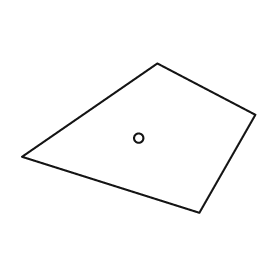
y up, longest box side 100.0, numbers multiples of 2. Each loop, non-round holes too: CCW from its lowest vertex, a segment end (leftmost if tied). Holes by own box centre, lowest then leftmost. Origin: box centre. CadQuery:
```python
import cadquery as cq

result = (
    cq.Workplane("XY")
    .moveTo(26.0, -32.0)
    .lineTo(50.0, 10.0)
    .lineTo(8.0, 32.0)
    .lineTo(-50.0, -8.0)
    .close()
    .moveTo(0.0, 0.0)
    .circle(2.0)
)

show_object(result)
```